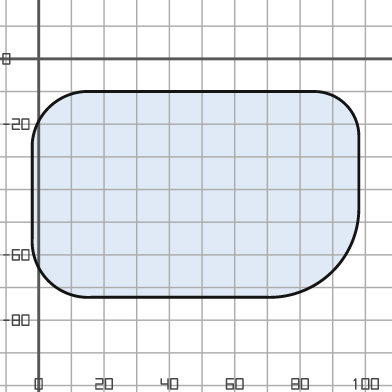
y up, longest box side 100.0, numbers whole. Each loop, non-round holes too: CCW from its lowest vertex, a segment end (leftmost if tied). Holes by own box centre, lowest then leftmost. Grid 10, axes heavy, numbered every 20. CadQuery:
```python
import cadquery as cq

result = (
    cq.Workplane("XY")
    .moveTo(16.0, -73.0)
    .lineTo(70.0, -73.0)
    .threePointArc((90.0, -65.0), (98.0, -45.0))
    .lineTo(98.0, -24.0)
    .threePointArc((94.0, -14.0), (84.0, -10.0))
    .lineTo(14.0, -10.0)
    .threePointArc((3.0, -15.0), (-2.0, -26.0))
    .lineTo(-2.0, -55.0)
    .threePointArc((3.0, -68.0), (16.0, -73.0))
    .close()
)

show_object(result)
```